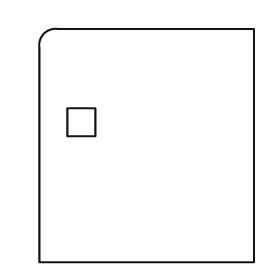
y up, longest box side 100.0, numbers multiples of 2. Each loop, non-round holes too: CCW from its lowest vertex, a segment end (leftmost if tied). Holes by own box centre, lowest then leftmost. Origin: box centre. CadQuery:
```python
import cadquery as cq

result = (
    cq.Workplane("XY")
    .moveTo(-46.0, -50.0)
    .lineTo(46.0, -50.0)
    .lineTo(46.0, 50.0)
    .lineTo(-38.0, 50.0)
    .threePointArc((-44.0, 48.0), (-46.0, 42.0))
    .close()
    .moveTo(-34.0, 4.0)
    .lineTo(-22.0, 4.0)
    .lineTo(-22.0, 16.0)
    .lineTo(-34.0, 16.0)
    .close()
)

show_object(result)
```